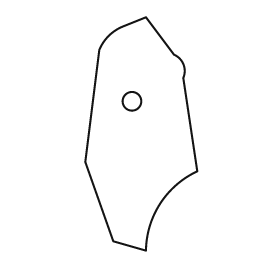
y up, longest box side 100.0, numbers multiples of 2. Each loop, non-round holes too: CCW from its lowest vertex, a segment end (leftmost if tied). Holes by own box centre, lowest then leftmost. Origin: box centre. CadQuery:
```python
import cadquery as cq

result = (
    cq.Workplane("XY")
    .moveTo(2.0, -50.0)
    .threePointArc((8.0, -30.0), (24.0, -16.0))
    .lineTo(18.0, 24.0)
    .threePointArc((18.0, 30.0), (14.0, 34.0))
    .lineTo(2.0, 50.0)
    .lineTo(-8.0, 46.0)
    .threePointArc((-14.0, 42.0), (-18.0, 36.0))
    .lineTo(-24.0, -12.0)
    .lineTo(-12.0, -46.0)
    .close()
    .moveTo(-4.0, 14.0)
    .circle(4.0)
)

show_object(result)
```